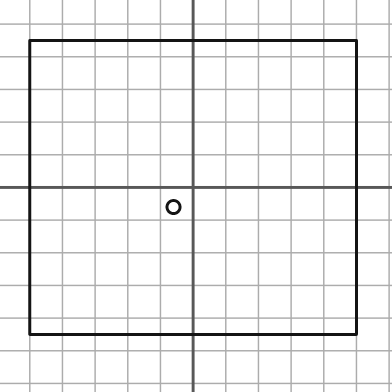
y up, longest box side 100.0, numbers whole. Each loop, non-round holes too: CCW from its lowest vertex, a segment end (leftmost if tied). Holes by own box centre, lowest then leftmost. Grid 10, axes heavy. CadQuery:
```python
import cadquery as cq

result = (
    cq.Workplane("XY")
    .moveTo(-50.0, -45.0)
    .lineTo(50.0, -45.0)
    .lineTo(50.0, 45.0)
    .lineTo(-50.0, 45.0)
    .close()
    .moveTo(-6.0, -6.0)
    .circle(2.0)
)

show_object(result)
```